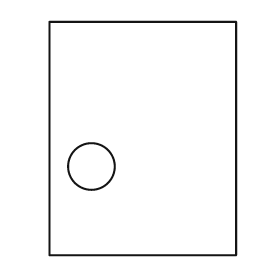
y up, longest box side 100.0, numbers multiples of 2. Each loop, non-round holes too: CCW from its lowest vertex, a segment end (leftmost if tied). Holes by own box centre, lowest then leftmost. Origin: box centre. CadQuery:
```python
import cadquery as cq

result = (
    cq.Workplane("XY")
    .moveTo(-40.0, -50.0)
    .lineTo(40.0, -50.0)
    .lineTo(40.0, 50.0)
    .lineTo(-40.0, 50.0)
    .close()
    .moveTo(-22.0, -12.0)
    .circle(10.0)
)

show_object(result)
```